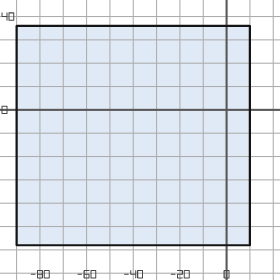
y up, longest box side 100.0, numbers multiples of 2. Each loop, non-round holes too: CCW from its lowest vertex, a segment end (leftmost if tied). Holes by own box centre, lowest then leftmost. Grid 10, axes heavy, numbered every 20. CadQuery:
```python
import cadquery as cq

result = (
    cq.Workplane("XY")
    .moveTo(-90.0, -58.0)
    .lineTo(10.0, -58.0)
    .lineTo(10.0, 36.0)
    .lineTo(-90.0, 36.0)
    .close()
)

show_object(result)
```